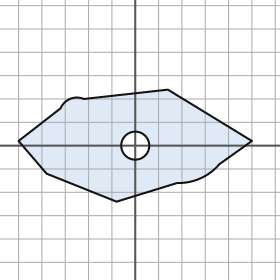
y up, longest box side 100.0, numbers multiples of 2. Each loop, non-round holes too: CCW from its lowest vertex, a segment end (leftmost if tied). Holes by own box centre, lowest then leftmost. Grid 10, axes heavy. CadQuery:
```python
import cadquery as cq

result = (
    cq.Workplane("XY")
    .moveTo(-8.0, -24.0)
    .lineTo(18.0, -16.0)
    .threePointArc((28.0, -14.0), (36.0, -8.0))
    .lineTo(50.0, 2.0)
    .lineTo(14.0, 24.0)
    .lineTo(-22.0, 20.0)
    .threePointArc((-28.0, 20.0), (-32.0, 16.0))
    .lineTo(-50.0, 2.0)
    .lineTo(-38.0, -12.0)
    .close()
    .moveTo(0.0, 0.0)
    .circle(6.0)
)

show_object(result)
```